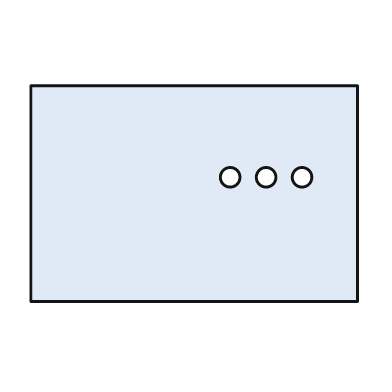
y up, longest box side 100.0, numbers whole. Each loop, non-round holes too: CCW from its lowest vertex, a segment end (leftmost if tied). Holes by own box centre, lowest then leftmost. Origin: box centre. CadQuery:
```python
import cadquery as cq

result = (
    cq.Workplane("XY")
    .moveTo(-50.0, -33.0)
    .lineTo(50.0, -33.0)
    .lineTo(50.0, 33.0)
    .lineTo(-50.0, 33.0)
    .close()
    .moveTo(11.0, 5.0)
    .circle(3.0)
    .moveTo(22.0, 5.0)
    .circle(3.0)
    .moveTo(33.0, 5.0)
    .circle(3.0)
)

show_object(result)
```